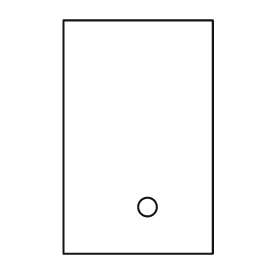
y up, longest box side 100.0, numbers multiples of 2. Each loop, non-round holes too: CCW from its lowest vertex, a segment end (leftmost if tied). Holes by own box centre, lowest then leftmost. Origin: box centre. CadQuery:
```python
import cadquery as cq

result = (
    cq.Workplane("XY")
    .moveTo(-32.0, -50.0)
    .lineTo(32.0, -50.0)
    .lineTo(32.0, 50.0)
    .lineTo(-32.0, 50.0)
    .close()
    .moveTo(4.0, -30.0)
    .circle(4.0)
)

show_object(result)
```